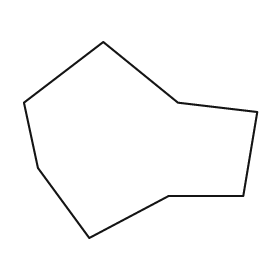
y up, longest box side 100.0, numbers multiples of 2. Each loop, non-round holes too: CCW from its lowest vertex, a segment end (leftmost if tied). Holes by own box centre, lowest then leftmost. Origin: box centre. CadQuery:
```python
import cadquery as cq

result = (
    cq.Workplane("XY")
    .moveTo(-22.0, -42.0)
    .lineTo(12.0, -24.0)
    .lineTo(44.0, -24.0)
    .lineTo(50.0, 12.0)
    .lineTo(16.0, 16.0)
    .lineTo(-16.0, 42.0)
    .lineTo(-50.0, 16.0)
    .lineTo(-44.0, -12.0)
    .close()
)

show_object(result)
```